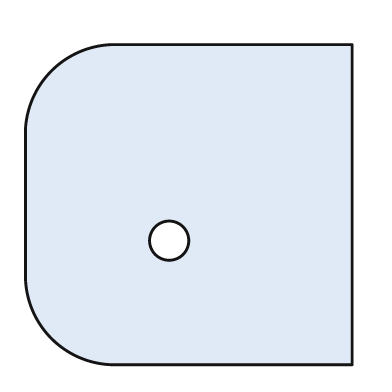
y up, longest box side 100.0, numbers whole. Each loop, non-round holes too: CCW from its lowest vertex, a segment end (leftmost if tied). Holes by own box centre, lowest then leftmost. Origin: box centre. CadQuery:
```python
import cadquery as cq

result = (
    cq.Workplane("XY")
    .moveTo(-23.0, -49.0)
    .lineTo(50.0, -49.0)
    .lineTo(50.0, 49.0)
    .lineTo(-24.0, 49.0)
    .threePointArc((-42.0, 41.0), (-50.0, 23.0))
    .lineTo(-50.0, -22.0)
    .threePointArc((-42.0, -41.0), (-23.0, -49.0))
    .close()
    .moveTo(-6.0, -11.0)
    .circle(6.0)
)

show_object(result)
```